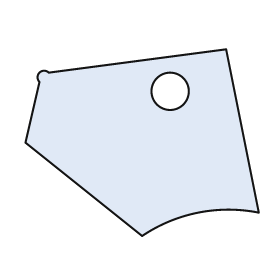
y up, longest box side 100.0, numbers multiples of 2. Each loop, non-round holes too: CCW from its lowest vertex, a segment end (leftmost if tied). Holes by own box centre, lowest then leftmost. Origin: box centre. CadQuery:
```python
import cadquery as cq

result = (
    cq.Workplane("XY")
    .moveTo(0.0, -40.0)
    .threePointArc((24.0, -30.0), (50.0, -30.0))
    .lineTo(36.0, 40.0)
    .lineTo(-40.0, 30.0)
    .threePointArc((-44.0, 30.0), (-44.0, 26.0))
    .lineTo(-50.0, 0.0)
    .close()
    .moveTo(12.0, 22.0)
    .circle(8.0)
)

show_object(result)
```